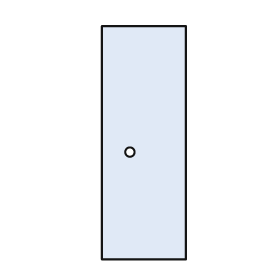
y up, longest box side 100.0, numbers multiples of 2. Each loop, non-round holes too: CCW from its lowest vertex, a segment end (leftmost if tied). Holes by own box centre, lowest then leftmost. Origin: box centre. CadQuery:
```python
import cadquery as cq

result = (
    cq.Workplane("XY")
    .moveTo(-18.0, -50.0)
    .lineTo(18.0, -50.0)
    .lineTo(18.0, 50.0)
    .lineTo(-18.0, 50.0)
    .close()
    .moveTo(-6.0, -4.0)
    .circle(2.0)
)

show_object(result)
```